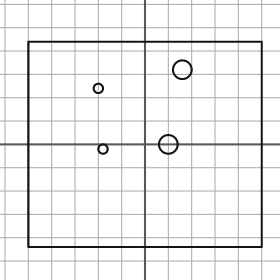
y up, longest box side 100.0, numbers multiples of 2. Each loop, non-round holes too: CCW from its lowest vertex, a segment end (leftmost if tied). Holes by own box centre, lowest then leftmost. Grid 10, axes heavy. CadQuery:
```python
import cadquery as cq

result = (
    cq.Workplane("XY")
    .moveTo(-50.0, -44.0)
    .lineTo(50.0, -44.0)
    .lineTo(50.0, 44.0)
    .lineTo(-50.0, 44.0)
    .close()
    .moveTo(-18.0, -2.0)
    .circle(2.0)
    .moveTo(10.0, 0.0)
    .circle(4.0)
    .moveTo(-20.0, 24.0)
    .circle(2.0)
    .moveTo(16.0, 32.0)
    .circle(4.0)
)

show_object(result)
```